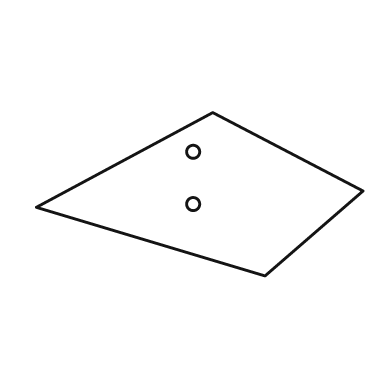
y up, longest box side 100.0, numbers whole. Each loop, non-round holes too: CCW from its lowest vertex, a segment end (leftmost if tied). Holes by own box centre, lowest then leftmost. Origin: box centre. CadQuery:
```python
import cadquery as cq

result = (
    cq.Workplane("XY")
    .moveTo(20.0, -25.0)
    .lineTo(50.0, 1.0)
    .lineTo(4.0, 25.0)
    .lineTo(-50.0, -4.0)
    .close()
    .moveTo(-2.0, -3.0)
    .circle(2.0)
    .moveTo(-2.0, 13.0)
    .circle(2.0)
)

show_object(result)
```